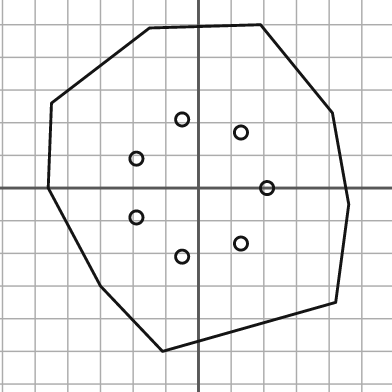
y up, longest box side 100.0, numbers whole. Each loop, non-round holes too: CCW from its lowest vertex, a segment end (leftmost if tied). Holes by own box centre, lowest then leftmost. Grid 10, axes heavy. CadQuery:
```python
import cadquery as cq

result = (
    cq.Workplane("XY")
    .moveTo(-11.0, -50.0)
    .lineTo(42.0, -35.0)
    .lineTo(46.0, -5.0)
    .lineTo(41.0, 23.0)
    .lineTo(19.0, 50.0)
    .lineTo(-15.0, 49.0)
    .lineTo(-45.0, 26.0)
    .lineTo(-46.0, 0.0)
    .lineTo(-30.0, -30.0)
    .close()
    .moveTo(-5.0, -21.0)
    .circle(2.0)
    .moveTo(13.0, -17.0)
    .circle(2.0)
    .moveTo(-19.0, -9.0)
    .circle(2.0)
    .moveTo(21.0, 0.0)
    .circle(2.0)
    .moveTo(-19.0, 9.0)
    .circle(2.0)
    .moveTo(13.0, 17.0)
    .circle(2.0)
    .moveTo(-5.0, 21.0)
    .circle(2.0)
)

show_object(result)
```